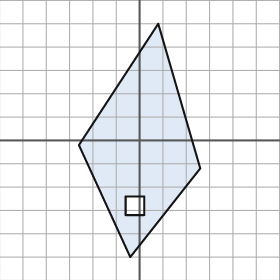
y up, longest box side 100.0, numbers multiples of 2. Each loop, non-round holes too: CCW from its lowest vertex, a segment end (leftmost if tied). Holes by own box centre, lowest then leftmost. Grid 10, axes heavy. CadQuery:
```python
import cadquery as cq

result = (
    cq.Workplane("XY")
    .moveTo(-4.0, -50.0)
    .lineTo(26.0, -12.0)
    .lineTo(8.0, 50.0)
    .lineTo(-26.0, -2.0)
    .close()
    .moveTo(-6.0, -32.0)
    .lineTo(2.0, -32.0)
    .lineTo(2.0, -24.0)
    .lineTo(-6.0, -24.0)
    .close()
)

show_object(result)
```